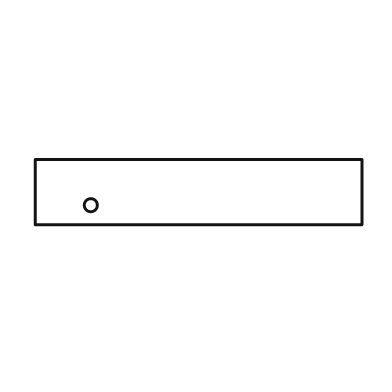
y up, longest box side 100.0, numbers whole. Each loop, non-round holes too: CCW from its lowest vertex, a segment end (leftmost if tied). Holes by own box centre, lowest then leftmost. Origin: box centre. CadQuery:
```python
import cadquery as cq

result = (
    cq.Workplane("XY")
    .moveTo(-50.0, -10.0)
    .lineTo(50.0, -10.0)
    .lineTo(50.0, 10.0)
    .lineTo(-50.0, 10.0)
    .close()
    .moveTo(-33.0, -4.0)
    .circle(2.0)
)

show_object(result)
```